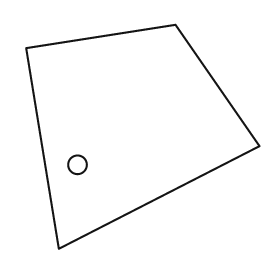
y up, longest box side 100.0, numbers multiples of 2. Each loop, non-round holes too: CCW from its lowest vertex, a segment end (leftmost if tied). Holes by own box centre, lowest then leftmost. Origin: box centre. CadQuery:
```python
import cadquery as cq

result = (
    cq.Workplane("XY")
    .moveTo(-36.0, -48.0)
    .lineTo(50.0, -4.0)
    .lineTo(14.0, 48.0)
    .lineTo(-50.0, 38.0)
    .close()
    .moveTo(-28.0, -12.0)
    .circle(4.0)
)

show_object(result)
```